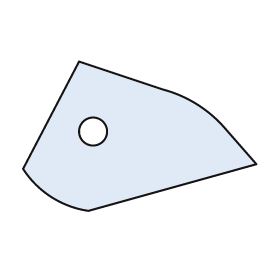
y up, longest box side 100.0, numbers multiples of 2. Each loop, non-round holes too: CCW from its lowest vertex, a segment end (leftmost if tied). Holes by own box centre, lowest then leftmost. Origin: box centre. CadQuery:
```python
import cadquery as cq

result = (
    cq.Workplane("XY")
    .moveTo(-22.0, -32.0)
    .lineTo(50.0, -12.0)
    .lineTo(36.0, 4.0)
    .threePointArc((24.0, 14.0), (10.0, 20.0))
    .lineTo(-26.0, 32.0)
    .lineTo(-50.0, -14.0)
    .threePointArc((-38.0, -26.0), (-22.0, -32.0))
    .close()
    .moveTo(-20.0, 2.0)
    .circle(6.0)
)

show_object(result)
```